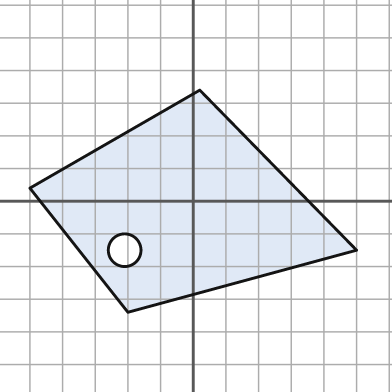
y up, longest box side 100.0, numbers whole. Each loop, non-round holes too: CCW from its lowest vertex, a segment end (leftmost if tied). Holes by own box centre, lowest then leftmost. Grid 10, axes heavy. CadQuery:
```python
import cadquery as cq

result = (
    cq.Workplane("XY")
    .moveTo(-20.0, -34.0)
    .lineTo(50.0, -15.0)
    .lineTo(2.0, 34.0)
    .lineTo(-50.0, 4.0)
    .close()
    .moveTo(-21.0, -15.0)
    .circle(5.0)
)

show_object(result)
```